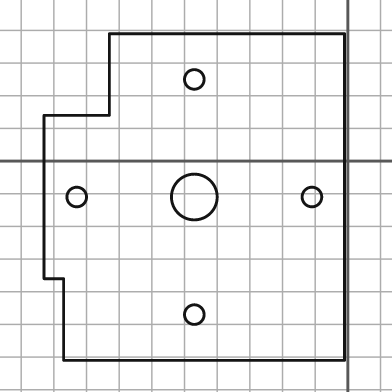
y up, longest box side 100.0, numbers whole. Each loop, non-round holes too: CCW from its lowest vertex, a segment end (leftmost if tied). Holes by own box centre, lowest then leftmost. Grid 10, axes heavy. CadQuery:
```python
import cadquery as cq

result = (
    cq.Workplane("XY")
    .moveTo(-87.0, -61.0)
    .lineTo(-1.0, -61.0)
    .lineTo(-1.0, 39.0)
    .lineTo(-73.0, 39.0)
    .lineTo(-73.0, 14.0)
    .lineTo(-93.0, 14.0)
    .lineTo(-93.0, -36.0)
    .lineTo(-87.0, -36.0)
    .close()
    .moveTo(-47.0, -47.0)
    .circle(3.0)
    .moveTo(-83.0, -11.0)
    .circle(3.0)
    .moveTo(-47.0, -11.0)
    .circle(7.0)
    .moveTo(-11.0, -11.0)
    .circle(3.0)
    .moveTo(-47.0, 25.0)
    .circle(3.0)
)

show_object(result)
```